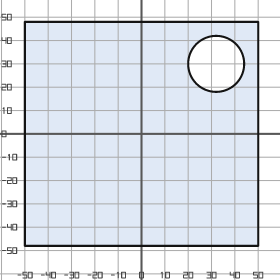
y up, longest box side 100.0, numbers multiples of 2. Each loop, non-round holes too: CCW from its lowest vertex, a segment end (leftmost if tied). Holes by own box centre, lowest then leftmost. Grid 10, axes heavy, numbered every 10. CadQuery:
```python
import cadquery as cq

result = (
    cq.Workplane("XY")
    .moveTo(-50.0, -48.0)
    .lineTo(50.0, -48.0)
    .lineTo(50.0, 48.0)
    .lineTo(-50.0, 48.0)
    .close()
    .moveTo(32.0, 30.0)
    .circle(12.0)
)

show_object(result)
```